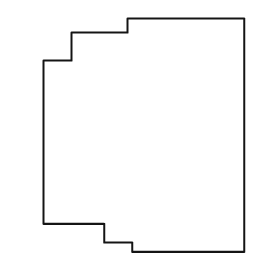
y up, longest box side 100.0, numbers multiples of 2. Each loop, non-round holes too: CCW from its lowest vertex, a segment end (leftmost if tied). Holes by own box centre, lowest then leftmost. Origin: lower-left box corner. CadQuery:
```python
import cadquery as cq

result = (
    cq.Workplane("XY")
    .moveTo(38.0, 0.0)
    .lineTo(86.0, 0.0)
    .lineTo(86.0, 100.0)
    .lineTo(36.0, 100.0)
    .lineTo(36.0, 94.0)
    .lineTo(12.0, 94.0)
    .lineTo(12.0, 82.0)
    .lineTo(0.0, 82.0)
    .lineTo(0.0, 12.0)
    .lineTo(26.0, 12.0)
    .lineTo(26.0, 4.0)
    .lineTo(38.0, 4.0)
    .close()
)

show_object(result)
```